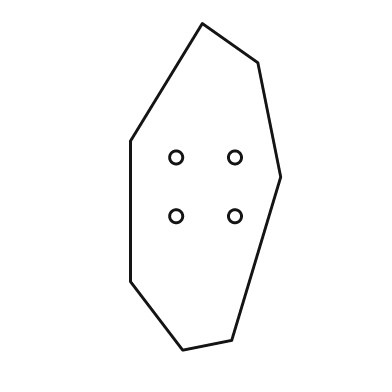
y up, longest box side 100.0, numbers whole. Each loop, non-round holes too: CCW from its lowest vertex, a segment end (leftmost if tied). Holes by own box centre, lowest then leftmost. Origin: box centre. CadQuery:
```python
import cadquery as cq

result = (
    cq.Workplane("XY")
    .moveTo(-7.0, -50.0)
    .lineTo(8.0, -47.0)
    .lineTo(23.0, 3.0)
    .lineTo(16.0, 38.0)
    .lineTo(-1.0, 50.0)
    .lineTo(-23.0, 14.0)
    .lineTo(-23.0, -29.0)
    .close()
    .moveTo(-9.0, -9.0)
    .circle(2.0)
    .moveTo(9.0, -9.0)
    .circle(2.0)
    .moveTo(-9.0, 9.0)
    .circle(2.0)
    .moveTo(9.0, 9.0)
    .circle(2.0)
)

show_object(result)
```